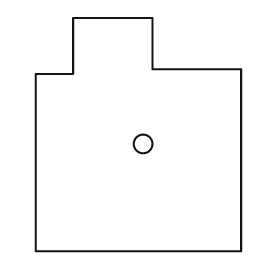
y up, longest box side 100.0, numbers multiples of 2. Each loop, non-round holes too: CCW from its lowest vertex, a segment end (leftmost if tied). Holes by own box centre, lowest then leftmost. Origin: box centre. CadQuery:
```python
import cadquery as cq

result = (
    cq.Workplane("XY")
    .moveTo(-44.0, -50.0)
    .lineTo(44.0, -50.0)
    .lineTo(44.0, 28.0)
    .lineTo(6.0, 28.0)
    .lineTo(6.0, 50.0)
    .lineTo(-28.0, 50.0)
    .lineTo(-28.0, 26.0)
    .lineTo(-44.0, 26.0)
    .close()
    .moveTo(2.0, -4.0)
    .circle(4.0)
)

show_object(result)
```